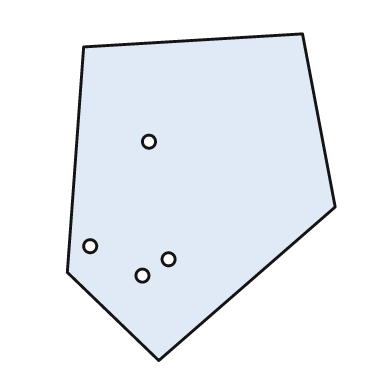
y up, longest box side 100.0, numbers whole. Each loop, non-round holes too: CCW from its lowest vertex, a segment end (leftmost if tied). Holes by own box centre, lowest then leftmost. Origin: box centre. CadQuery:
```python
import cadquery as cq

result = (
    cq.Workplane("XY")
    .moveTo(-13.0, -50.0)
    .lineTo(41.0, -3.0)
    .lineTo(31.0, 50.0)
    .lineTo(-36.0, 46.0)
    .lineTo(-41.0, -23.0)
    .close()
    .moveTo(-18.0, -24.0)
    .circle(2.0)
    .moveTo(-10.0, -19.0)
    .circle(2.0)
    .moveTo(-34.0, -15.0)
    .circle(2.0)
    .moveTo(-16.0, 17.0)
    .circle(2.0)
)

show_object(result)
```